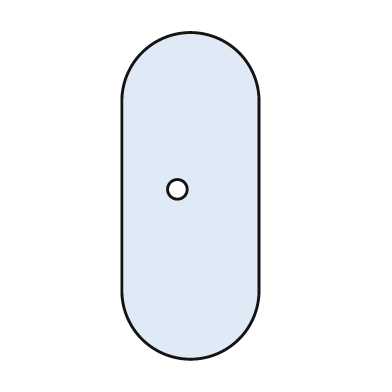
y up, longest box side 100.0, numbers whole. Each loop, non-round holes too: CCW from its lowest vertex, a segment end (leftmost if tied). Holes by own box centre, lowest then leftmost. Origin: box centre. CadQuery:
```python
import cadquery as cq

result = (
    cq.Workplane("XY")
    .moveTo(-21.0, -29.0)
    .threePointArc((0.0, -50.0), (21.0, -29.0))
    .lineTo(21.0, 29.0)
    .threePointArc((0.0, 50.0), (-21.0, 29.0))
    .close()
    .moveTo(-4.0, 2.0)
    .circle(3.0)
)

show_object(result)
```